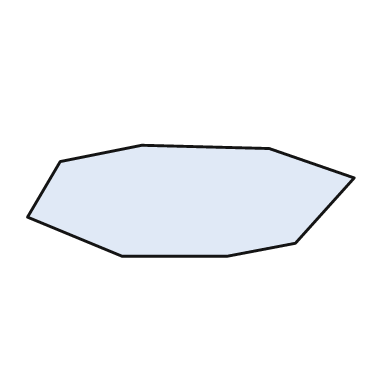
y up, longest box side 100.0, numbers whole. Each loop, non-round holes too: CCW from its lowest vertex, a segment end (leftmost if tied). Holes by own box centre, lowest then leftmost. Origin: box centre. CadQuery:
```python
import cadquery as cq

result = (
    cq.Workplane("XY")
    .moveTo(-21.0, -17.0)
    .lineTo(11.0, -17.0)
    .lineTo(32.0, -13.0)
    .lineTo(50.0, 7.0)
    .lineTo(24.0, 16.0)
    .lineTo(-15.0, 17.0)
    .lineTo(-40.0, 12.0)
    .lineTo(-50.0, -5.0)
    .close()
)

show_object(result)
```